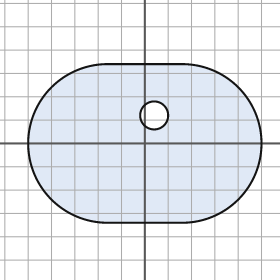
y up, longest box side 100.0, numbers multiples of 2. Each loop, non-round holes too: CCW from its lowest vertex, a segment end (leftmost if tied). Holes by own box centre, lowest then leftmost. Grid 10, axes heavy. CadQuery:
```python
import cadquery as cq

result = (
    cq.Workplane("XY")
    .moveTo(-16.0, -34.0)
    .lineTo(16.0, -34.0)
    .threePointArc((50.0, 0.0), (16.0, 34.0))
    .lineTo(-16.0, 34.0)
    .threePointArc((-50.0, 0.0), (-16.0, -34.0))
    .close()
    .moveTo(4.0, 12.0)
    .circle(6.0)
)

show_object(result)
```